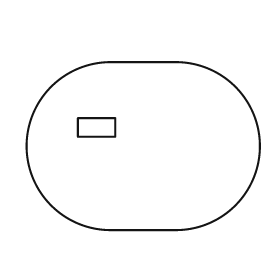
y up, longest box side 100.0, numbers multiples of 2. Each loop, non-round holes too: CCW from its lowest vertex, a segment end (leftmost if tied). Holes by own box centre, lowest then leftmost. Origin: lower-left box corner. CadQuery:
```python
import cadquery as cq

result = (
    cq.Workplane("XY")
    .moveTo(36.0, 0.0)
    .lineTo(64.0, 0.0)
    .threePointArc((100.0, 36.0), (64.0, 72.0))
    .lineTo(36.0, 72.0)
    .threePointArc((0.0, 36.0), (36.0, 0.0))
    .close()
    .moveTo(22.0, 40.0)
    .lineTo(38.0, 40.0)
    .lineTo(38.0, 48.0)
    .lineTo(22.0, 48.0)
    .close()
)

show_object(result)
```